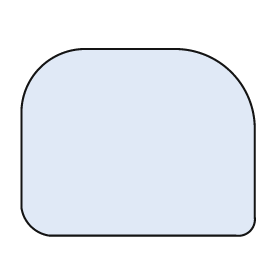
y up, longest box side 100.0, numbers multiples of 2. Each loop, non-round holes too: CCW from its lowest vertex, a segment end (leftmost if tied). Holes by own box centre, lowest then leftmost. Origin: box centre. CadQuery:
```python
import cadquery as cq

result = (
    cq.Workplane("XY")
    .moveTo(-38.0, -40.0)
    .lineTo(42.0, -40.0)
    .threePointArc((48.0, -38.0), (50.0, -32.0))
    .lineTo(50.0, 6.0)
    .threePointArc((40.0, 30.0), (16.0, 40.0))
    .lineTo(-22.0, 40.0)
    .threePointArc((-42.0, 32.0), (-50.0, 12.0))
    .lineTo(-50.0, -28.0)
    .threePointArc((-46.0, -36.0), (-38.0, -40.0))
    .close()
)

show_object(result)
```